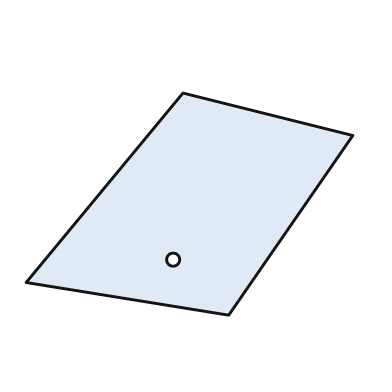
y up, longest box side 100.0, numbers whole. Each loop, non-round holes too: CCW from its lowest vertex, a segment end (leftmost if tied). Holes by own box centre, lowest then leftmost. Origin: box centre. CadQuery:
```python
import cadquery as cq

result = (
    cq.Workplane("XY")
    .moveTo(12.0, -34.0)
    .lineTo(50.0, 21.0)
    .lineTo(-2.0, 34.0)
    .lineTo(-50.0, -24.0)
    .close()
    .moveTo(-5.0, -17.0)
    .circle(2.0)
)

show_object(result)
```